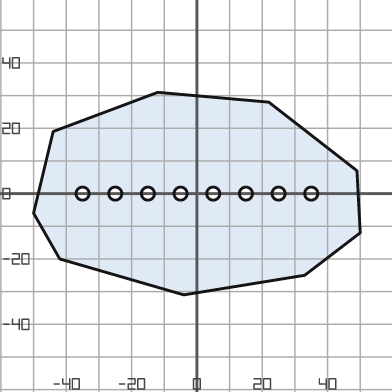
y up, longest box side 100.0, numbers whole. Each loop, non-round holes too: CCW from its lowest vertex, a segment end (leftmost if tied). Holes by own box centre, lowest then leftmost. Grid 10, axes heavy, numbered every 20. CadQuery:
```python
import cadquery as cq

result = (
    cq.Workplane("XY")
    .moveTo(-4.0, -31.0)
    .lineTo(33.0, -25.0)
    .lineTo(50.0, -12.0)
    .lineTo(49.0, 7.0)
    .lineTo(22.0, 28.0)
    .lineTo(-12.0, 31.0)
    .lineTo(-44.0, 19.0)
    .lineTo(-50.0, -6.0)
    .lineTo(-42.0, -20.0)
    .close()
    .moveTo(-35.0, 0.0)
    .circle(2.0)
    .moveTo(-25.0, 0.0)
    .circle(2.0)
    .moveTo(-15.0, 0.0)
    .circle(2.0)
    .moveTo(-5.0, 0.0)
    .circle(2.0)
    .moveTo(5.0, 0.0)
    .circle(2.0)
    .moveTo(15.0, 0.0)
    .circle(2.0)
    .moveTo(25.0, 0.0)
    .circle(2.0)
    .moveTo(35.0, 0.0)
    .circle(2.0)
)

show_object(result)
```